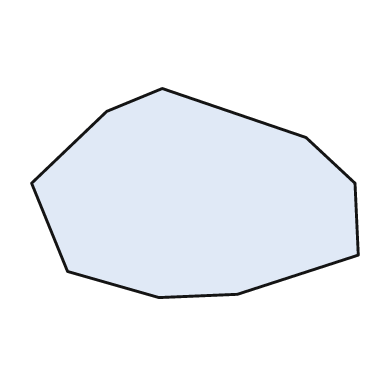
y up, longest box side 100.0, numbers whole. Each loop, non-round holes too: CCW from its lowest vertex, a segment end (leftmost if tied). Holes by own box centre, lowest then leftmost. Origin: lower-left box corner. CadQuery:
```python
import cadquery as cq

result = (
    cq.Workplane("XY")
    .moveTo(39.0, 0.0)
    .lineTo(63.0, 1.0)
    .lineTo(100.0, 13.0)
    .lineTo(99.0, 35.0)
    .lineTo(84.0, 49.0)
    .lineTo(40.0, 64.0)
    .lineTo(23.0, 57.0)
    .lineTo(0.0, 35.0)
    .lineTo(11.0, 8.0)
    .close()
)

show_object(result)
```